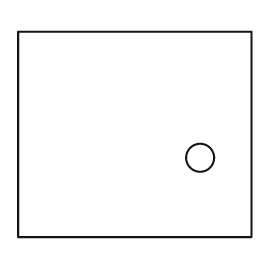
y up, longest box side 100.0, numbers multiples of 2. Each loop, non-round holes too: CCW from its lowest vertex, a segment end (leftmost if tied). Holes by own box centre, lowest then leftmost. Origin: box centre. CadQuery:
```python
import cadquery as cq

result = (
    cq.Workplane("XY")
    .moveTo(-50.0, -44.0)
    .lineTo(50.0, -44.0)
    .lineTo(50.0, 44.0)
    .lineTo(-50.0, 44.0)
    .close()
    .moveTo(28.0, -10.0)
    .circle(6.0)
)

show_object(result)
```